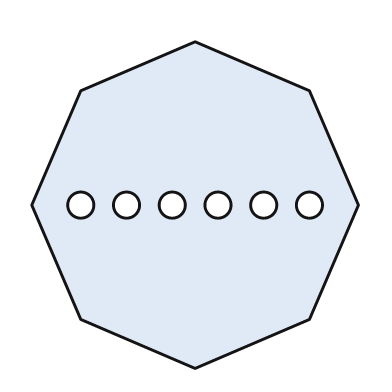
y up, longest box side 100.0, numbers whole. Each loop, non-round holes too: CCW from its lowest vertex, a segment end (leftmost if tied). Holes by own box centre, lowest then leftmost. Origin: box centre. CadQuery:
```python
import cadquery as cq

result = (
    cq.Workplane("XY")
    .moveTo(0.0, -50.0)
    .lineTo(35.0, -35.0)
    .lineTo(50.0, 0.0)
    .lineTo(35.0, 35.0)
    .lineTo(0.0, 50.0)
    .lineTo(-35.0, 35.0)
    .lineTo(-50.0, 0.0)
    .lineTo(-35.0, -35.0)
    .close()
    .moveTo(-35.0, 0.0)
    .circle(4.0)
    .moveTo(-21.0, 0.0)
    .circle(4.0)
    .moveTo(-7.0, 0.0)
    .circle(4.0)
    .moveTo(7.0, 0.0)
    .circle(4.0)
    .moveTo(21.0, 0.0)
    .circle(4.0)
    .moveTo(35.0, 0.0)
    .circle(4.0)
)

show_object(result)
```